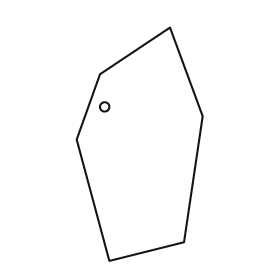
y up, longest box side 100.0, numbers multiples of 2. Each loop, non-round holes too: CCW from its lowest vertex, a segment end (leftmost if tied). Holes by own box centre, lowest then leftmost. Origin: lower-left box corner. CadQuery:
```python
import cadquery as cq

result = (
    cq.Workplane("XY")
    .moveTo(14.0, 0.0)
    .lineTo(46.0, 8.0)
    .lineTo(54.0, 62.0)
    .lineTo(40.0, 100.0)
    .lineTo(10.0, 80.0)
    .lineTo(0.0, 52.0)
    .close()
    .moveTo(12.0, 66.0)
    .circle(2.0)
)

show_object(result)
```